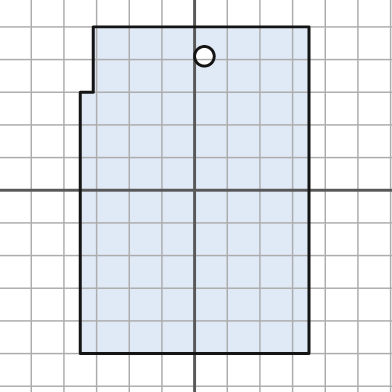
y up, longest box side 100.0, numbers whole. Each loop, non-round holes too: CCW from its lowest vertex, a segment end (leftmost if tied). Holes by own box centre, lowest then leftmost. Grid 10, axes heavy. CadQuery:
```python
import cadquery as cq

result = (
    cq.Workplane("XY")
    .moveTo(-35.0, -50.0)
    .lineTo(35.0, -50.0)
    .lineTo(35.0, 50.0)
    .lineTo(-31.0, 50.0)
    .lineTo(-31.0, 30.0)
    .lineTo(-35.0, 30.0)
    .close()
    .moveTo(3.0, 41.0)
    .circle(3.0)
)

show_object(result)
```